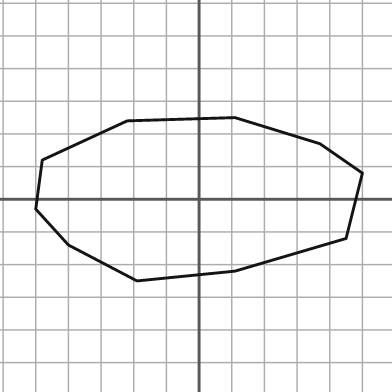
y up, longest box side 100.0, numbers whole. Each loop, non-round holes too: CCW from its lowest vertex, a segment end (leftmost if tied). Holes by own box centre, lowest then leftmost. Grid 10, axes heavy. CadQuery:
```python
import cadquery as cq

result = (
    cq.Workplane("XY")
    .moveTo(-19.0, -25.0)
    .lineTo(11.0, -22.0)
    .lineTo(45.0, -12.0)
    .lineTo(50.0, 8.0)
    .lineTo(37.0, 17.0)
    .lineTo(11.0, 25.0)
    .lineTo(-22.0, 24.0)
    .lineTo(-48.0, 12.0)
    .lineTo(-50.0, -3.0)
    .lineTo(-40.0, -14.0)
    .close()
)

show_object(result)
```